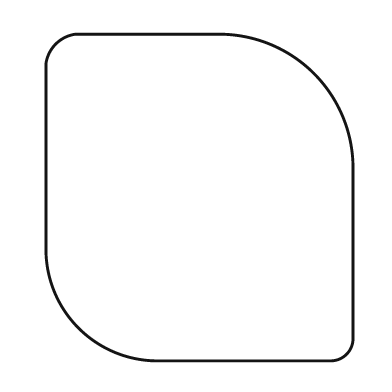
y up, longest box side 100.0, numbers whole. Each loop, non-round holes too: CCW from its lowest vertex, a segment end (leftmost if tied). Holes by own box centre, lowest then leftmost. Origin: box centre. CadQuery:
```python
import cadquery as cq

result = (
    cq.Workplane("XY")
    .moveTo(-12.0, -50.0)
    .lineTo(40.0, -50.0)
    .threePointArc((45.0, -48.0), (47.0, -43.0))
    .lineTo(47.0, 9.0)
    .threePointArc((35.0, 38.0), (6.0, 50.0))
    .lineTo(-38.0, 50.0)
    .threePointArc((-44.0, 47.0), (-47.0, 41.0))
    .lineTo(-47.0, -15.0)
    .threePointArc((-37.0, -40.0), (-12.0, -50.0))
    .close()
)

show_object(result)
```